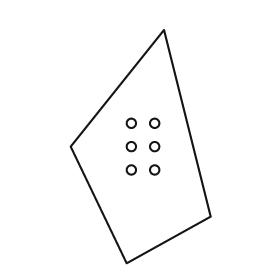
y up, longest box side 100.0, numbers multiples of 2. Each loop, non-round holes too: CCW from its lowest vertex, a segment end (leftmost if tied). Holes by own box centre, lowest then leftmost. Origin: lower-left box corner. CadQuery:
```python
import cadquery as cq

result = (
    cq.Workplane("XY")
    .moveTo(24.0, 0.0)
    .lineTo(60.0, 20.0)
    .lineTo(40.0, 100.0)
    .lineTo(0.0, 50.0)
    .close()
    .moveTo(26.0, 40.0)
    .circle(2.0)
    .moveTo(36.0, 40.0)
    .circle(2.0)
    .moveTo(26.0, 50.0)
    .circle(2.0)
    .moveTo(36.0, 50.0)
    .circle(2.0)
    .moveTo(26.0, 60.0)
    .circle(2.0)
    .moveTo(36.0, 60.0)
    .circle(2.0)
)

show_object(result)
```